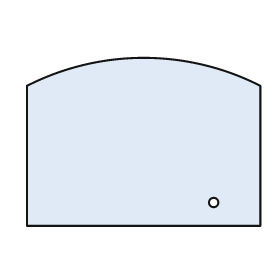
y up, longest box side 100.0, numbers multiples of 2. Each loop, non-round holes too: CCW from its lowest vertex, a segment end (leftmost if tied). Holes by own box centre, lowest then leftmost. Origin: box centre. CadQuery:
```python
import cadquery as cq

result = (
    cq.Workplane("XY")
    .moveTo(-50.0, -36.0)
    .lineTo(50.0, -36.0)
    .lineTo(50.0, 24.0)
    .threePointArc((0.0, 36.0), (-50.0, 24.0))
    .close()
    .moveTo(30.0, -26.0)
    .circle(2.0)
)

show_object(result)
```